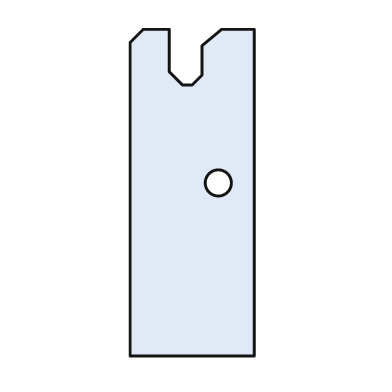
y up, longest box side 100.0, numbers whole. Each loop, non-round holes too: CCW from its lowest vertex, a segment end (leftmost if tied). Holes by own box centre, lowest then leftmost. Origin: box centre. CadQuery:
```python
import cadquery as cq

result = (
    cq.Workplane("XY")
    .moveTo(-19.0, -50.0)
    .lineTo(19.0, -50.0)
    .lineTo(19.0, 50.0)
    .lineTo(9.0, 50.0)
    .lineTo(3.0, 45.0)
    .lineTo(3.0, 36.0)
    .lineTo(0.0, 33.0)
    .lineTo(-3.0, 33.0)
    .lineTo(-7.0, 37.0)
    .lineTo(-7.0, 50.0)
    .lineTo(-15.0, 50.0)
    .lineTo(-19.0, 46.0)
    .close()
    .moveTo(8.0, 3.0)
    .circle(4.0)
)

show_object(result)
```